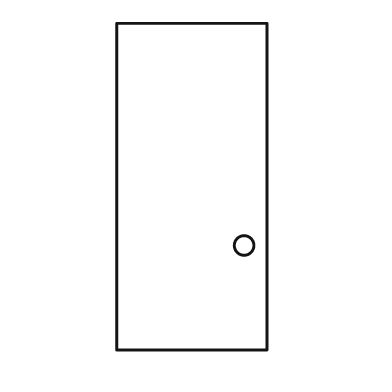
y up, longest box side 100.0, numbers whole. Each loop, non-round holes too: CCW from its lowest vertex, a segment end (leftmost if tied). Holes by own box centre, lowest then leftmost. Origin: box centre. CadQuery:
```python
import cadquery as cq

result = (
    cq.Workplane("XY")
    .moveTo(-23.0, -50.0)
    .lineTo(23.0, -50.0)
    .lineTo(23.0, 50.0)
    .lineTo(-23.0, 50.0)
    .close()
    .moveTo(16.0, -18.0)
    .circle(3.0)
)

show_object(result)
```